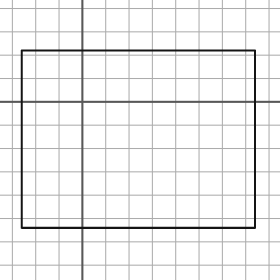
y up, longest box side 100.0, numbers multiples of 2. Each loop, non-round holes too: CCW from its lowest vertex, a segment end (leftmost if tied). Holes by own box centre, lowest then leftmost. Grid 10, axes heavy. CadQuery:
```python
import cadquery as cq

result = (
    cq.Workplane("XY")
    .moveTo(-26.0, -54.0)
    .lineTo(74.0, -54.0)
    .lineTo(74.0, 22.0)
    .lineTo(-26.0, 22.0)
    .close()
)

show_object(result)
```